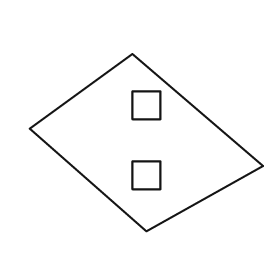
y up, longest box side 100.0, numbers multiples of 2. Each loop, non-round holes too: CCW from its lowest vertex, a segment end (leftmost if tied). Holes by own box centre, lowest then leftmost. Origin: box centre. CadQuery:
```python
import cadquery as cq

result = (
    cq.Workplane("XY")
    .moveTo(0.0, -38.0)
    .lineTo(50.0, -10.0)
    .lineTo(-6.0, 38.0)
    .lineTo(-50.0, 6.0)
    .close()
    .moveTo(-6.0, -20.0)
    .lineTo(6.0, -20.0)
    .lineTo(6.0, -8.0)
    .lineTo(-6.0, -8.0)
    .close()
    .moveTo(-6.0, 10.0)
    .lineTo(6.0, 10.0)
    .lineTo(6.0, 22.0)
    .lineTo(-6.0, 22.0)
    .close()
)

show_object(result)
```